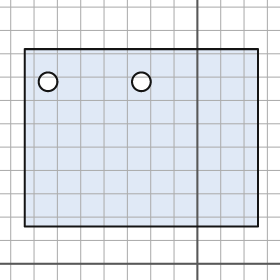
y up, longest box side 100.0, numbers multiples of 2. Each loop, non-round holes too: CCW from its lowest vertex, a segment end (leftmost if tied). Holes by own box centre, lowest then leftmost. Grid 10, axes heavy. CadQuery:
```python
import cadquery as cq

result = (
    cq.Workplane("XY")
    .moveTo(-74.0, 16.0)
    .lineTo(26.0, 16.0)
    .lineTo(26.0, 92.0)
    .lineTo(-74.0, 92.0)
    .close()
    .moveTo(-64.0, 78.0)
    .circle(4.0)
    .moveTo(-24.0, 78.0)
    .circle(4.0)
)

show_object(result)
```